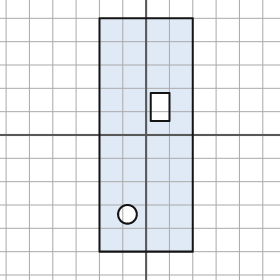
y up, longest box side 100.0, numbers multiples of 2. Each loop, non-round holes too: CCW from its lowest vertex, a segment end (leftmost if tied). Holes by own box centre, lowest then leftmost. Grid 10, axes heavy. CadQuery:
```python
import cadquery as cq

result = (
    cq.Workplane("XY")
    .moveTo(-20.0, -50.0)
    .lineTo(20.0, -50.0)
    .lineTo(20.0, 50.0)
    .lineTo(-20.0, 50.0)
    .close()
    .moveTo(-8.0, -34.0)
    .circle(4.0)
    .moveTo(2.0, 6.0)
    .lineTo(10.0, 6.0)
    .lineTo(10.0, 18.0)
    .lineTo(2.0, 18.0)
    .close()
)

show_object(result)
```